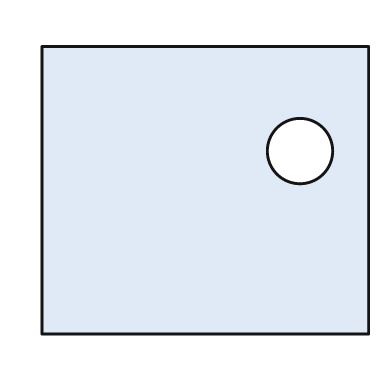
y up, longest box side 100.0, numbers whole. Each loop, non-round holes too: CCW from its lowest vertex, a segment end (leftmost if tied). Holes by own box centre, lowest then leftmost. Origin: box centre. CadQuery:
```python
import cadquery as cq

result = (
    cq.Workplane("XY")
    .moveTo(-50.0, -44.0)
    .lineTo(50.0, -44.0)
    .lineTo(50.0, 44.0)
    .lineTo(-50.0, 44.0)
    .close()
    .moveTo(29.0, 12.0)
    .circle(10.0)
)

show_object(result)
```